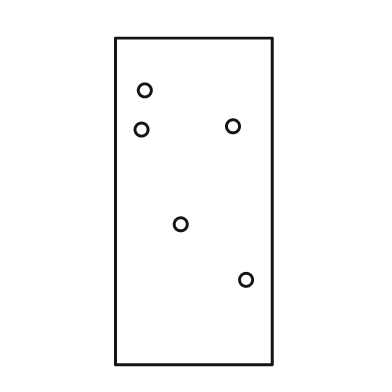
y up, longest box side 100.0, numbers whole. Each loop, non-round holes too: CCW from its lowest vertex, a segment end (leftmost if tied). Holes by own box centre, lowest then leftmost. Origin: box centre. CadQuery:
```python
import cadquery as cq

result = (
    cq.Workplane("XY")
    .moveTo(-24.0, -50.0)
    .lineTo(24.0, -50.0)
    .lineTo(24.0, 50.0)
    .lineTo(-24.0, 50.0)
    .close()
    .moveTo(16.0, -24.0)
    .circle(2.0)
    .moveTo(-4.0, -7.0)
    .circle(2.0)
    .moveTo(-16.0, 22.0)
    .circle(2.0)
    .moveTo(12.0, 23.0)
    .circle(2.0)
    .moveTo(-15.0, 34.0)
    .circle(2.0)
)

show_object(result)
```